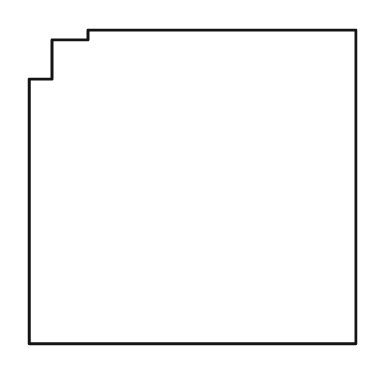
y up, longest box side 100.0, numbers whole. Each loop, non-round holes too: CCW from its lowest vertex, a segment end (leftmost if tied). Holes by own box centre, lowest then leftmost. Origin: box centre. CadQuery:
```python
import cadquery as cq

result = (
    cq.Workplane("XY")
    .moveTo(-50.0, -48.0)
    .lineTo(50.0, -48.0)
    .lineTo(50.0, 48.0)
    .lineTo(-32.0, 48.0)
    .lineTo(-32.0, 45.0)
    .lineTo(-43.0, 45.0)
    .lineTo(-43.0, 33.0)
    .lineTo(-50.0, 33.0)
    .close()
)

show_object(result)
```